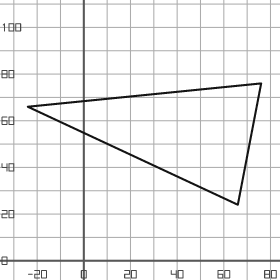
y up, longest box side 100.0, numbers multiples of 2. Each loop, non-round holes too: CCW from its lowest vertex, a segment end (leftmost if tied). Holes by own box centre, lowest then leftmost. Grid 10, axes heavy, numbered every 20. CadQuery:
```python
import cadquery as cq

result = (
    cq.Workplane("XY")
    .moveTo(66.0, 24.0)
    .lineTo(76.0, 76.0)
    .lineTo(-24.0, 66.0)
    .close()
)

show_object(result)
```